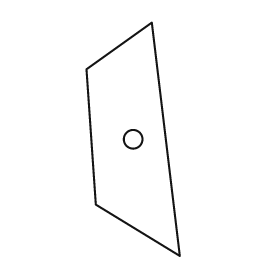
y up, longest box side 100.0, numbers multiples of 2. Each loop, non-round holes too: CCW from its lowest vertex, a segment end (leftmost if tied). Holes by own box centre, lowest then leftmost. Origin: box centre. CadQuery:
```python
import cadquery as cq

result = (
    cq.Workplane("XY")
    .moveTo(20.0, -50.0)
    .lineTo(8.0, 50.0)
    .lineTo(-20.0, 30.0)
    .lineTo(-16.0, -28.0)
    .close()
    .moveTo(0.0, 0.0)
    .circle(4.0)
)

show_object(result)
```